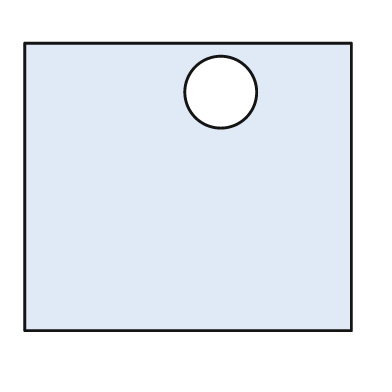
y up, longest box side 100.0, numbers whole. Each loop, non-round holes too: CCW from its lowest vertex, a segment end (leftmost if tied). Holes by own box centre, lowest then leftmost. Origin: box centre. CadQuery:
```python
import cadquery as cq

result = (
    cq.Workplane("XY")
    .moveTo(-50.0, -44.0)
    .lineTo(50.0, -44.0)
    .lineTo(50.0, 44.0)
    .lineTo(-50.0, 44.0)
    .close()
    .moveTo(10.0, 29.0)
    .circle(11.0)
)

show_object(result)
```